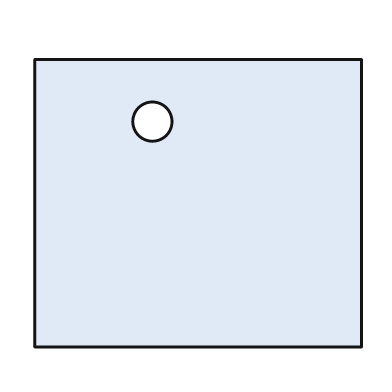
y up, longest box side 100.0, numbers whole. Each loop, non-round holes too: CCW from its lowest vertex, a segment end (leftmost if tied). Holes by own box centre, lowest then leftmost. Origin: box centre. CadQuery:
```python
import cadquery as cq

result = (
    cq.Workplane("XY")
    .moveTo(-50.0, -44.0)
    .lineTo(50.0, -44.0)
    .lineTo(50.0, 44.0)
    .lineTo(-50.0, 44.0)
    .close()
    .moveTo(-14.0, 25.0)
    .circle(6.0)
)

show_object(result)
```